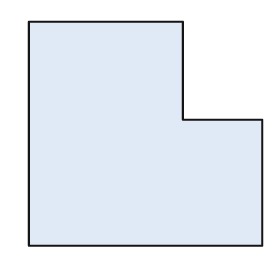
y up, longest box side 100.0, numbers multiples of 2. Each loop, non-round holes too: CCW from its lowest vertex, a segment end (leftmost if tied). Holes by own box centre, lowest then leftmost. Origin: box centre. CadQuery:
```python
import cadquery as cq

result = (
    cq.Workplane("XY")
    .moveTo(-50.0, -48.0)
    .lineTo(50.0, -48.0)
    .lineTo(50.0, 6.0)
    .lineTo(16.0, 6.0)
    .lineTo(16.0, 48.0)
    .lineTo(-50.0, 48.0)
    .close()
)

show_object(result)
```